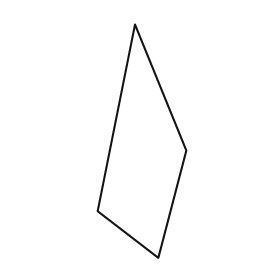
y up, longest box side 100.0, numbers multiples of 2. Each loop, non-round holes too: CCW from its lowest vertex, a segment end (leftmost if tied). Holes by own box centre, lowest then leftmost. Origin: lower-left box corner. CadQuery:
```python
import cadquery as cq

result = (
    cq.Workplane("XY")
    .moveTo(26.0, 0.0)
    .lineTo(38.0, 46.0)
    .lineTo(16.0, 100.0)
    .lineTo(0.0, 20.0)
    .close()
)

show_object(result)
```